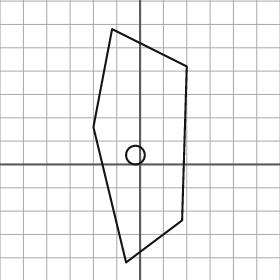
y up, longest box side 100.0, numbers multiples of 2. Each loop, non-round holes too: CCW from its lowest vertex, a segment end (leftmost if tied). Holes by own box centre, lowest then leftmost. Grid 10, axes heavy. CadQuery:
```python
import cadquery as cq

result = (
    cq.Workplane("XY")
    .moveTo(-6.0, -42.0)
    .lineTo(18.0, -24.0)
    .lineTo(20.0, 42.0)
    .lineTo(-12.0, 58.0)
    .lineTo(-20.0, 16.0)
    .close()
    .moveTo(-2.0, 4.0)
    .circle(4.0)
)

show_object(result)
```